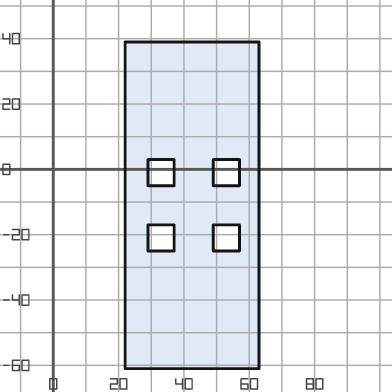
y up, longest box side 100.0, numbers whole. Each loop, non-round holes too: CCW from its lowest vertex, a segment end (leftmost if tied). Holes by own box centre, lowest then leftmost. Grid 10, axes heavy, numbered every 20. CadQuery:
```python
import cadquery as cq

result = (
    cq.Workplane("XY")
    .moveTo(22.0, -61.0)
    .lineTo(63.0, -61.0)
    .lineTo(63.0, 39.0)
    .lineTo(22.0, 39.0)
    .close()
    .moveTo(29.0, -25.0)
    .lineTo(37.0, -25.0)
    .lineTo(37.0, -17.0)
    .lineTo(29.0, -17.0)
    .close()
    .moveTo(49.0, -25.0)
    .lineTo(57.0, -25.0)
    .lineTo(57.0, -17.0)
    .lineTo(49.0, -17.0)
    .close()
    .moveTo(29.0, -5.0)
    .lineTo(37.0, -5.0)
    .lineTo(37.0, 3.0)
    .lineTo(29.0, 3.0)
    .close()
    .moveTo(49.0, -5.0)
    .lineTo(57.0, -5.0)
    .lineTo(57.0, 3.0)
    .lineTo(49.0, 3.0)
    .close()
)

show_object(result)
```